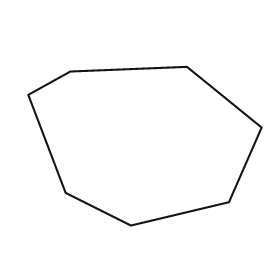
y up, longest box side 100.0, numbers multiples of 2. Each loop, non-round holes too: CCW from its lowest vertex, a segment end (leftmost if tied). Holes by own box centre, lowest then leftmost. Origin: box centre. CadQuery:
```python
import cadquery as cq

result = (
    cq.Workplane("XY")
    .moveTo(-6.0, -34.0)
    .lineTo(36.0, -24.0)
    .lineTo(50.0, 8.0)
    .lineTo(18.0, 34.0)
    .lineTo(-32.0, 32.0)
    .lineTo(-50.0, 22.0)
    .lineTo(-34.0, -20.0)
    .close()
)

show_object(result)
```